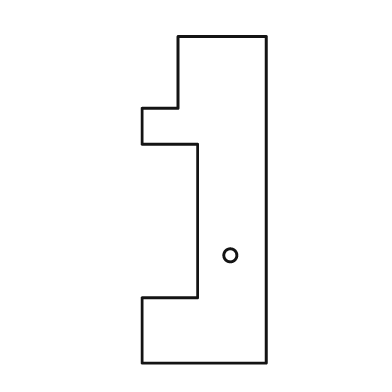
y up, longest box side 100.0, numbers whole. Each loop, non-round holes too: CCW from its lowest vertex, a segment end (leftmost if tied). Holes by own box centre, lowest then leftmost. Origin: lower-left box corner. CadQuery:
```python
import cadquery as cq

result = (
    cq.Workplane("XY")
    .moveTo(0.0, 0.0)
    .lineTo(38.0, 0.0)
    .lineTo(38.0, 100.0)
    .lineTo(11.0, 100.0)
    .lineTo(11.0, 78.0)
    .lineTo(0.0, 78.0)
    .lineTo(0.0, 67.0)
    .lineTo(17.0, 67.0)
    .lineTo(17.0, 20.0)
    .lineTo(0.0, 20.0)
    .close()
    .moveTo(27.0, 33.0)
    .circle(2.0)
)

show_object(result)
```